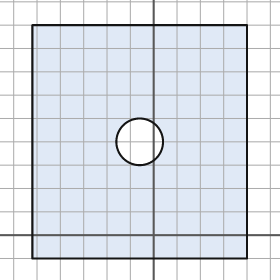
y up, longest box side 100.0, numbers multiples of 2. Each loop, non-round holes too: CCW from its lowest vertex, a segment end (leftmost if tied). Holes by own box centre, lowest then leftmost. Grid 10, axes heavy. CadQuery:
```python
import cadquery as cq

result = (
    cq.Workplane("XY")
    .moveTo(-52.0, -10.0)
    .lineTo(40.0, -10.0)
    .lineTo(40.0, 90.0)
    .lineTo(-52.0, 90.0)
    .close()
    .moveTo(-6.0, 40.0)
    .circle(10.0)
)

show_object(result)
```